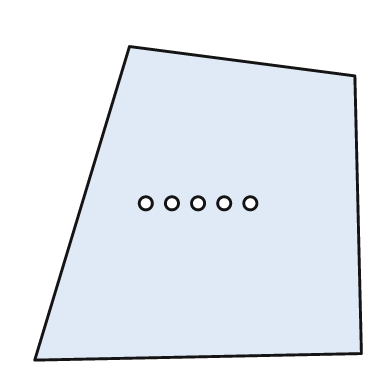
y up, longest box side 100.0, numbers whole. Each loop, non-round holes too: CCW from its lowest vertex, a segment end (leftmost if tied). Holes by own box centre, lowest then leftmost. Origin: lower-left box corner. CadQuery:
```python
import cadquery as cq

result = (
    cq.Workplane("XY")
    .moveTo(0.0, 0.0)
    .lineTo(100.0, 2.0)
    .lineTo(98.0, 87.0)
    .lineTo(29.0, 96.0)
    .close()
    .moveTo(34.0, 48.0)
    .circle(2.0)
    .moveTo(42.0, 48.0)
    .circle(2.0)
    .moveTo(50.0, 48.0)
    .circle(2.0)
    .moveTo(58.0, 48.0)
    .circle(2.0)
    .moveTo(66.0, 48.0)
    .circle(2.0)
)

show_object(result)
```